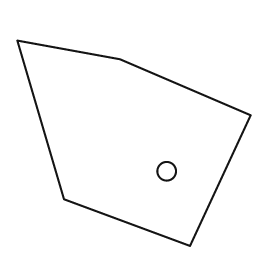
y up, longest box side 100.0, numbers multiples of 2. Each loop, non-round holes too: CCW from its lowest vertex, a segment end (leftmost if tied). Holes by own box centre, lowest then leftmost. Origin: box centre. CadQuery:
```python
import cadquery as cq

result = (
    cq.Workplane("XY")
    .moveTo(24.0, -44.0)
    .lineTo(50.0, 12.0)
    .lineTo(-6.0, 36.0)
    .lineTo(-50.0, 44.0)
    .lineTo(-30.0, -24.0)
    .close()
    .moveTo(14.0, -12.0)
    .circle(4.0)
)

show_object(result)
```